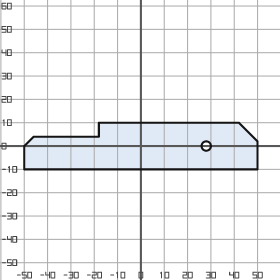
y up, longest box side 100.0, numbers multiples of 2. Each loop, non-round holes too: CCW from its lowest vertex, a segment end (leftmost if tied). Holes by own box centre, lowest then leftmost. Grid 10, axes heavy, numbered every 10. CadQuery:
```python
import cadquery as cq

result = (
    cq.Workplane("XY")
    .moveTo(-50.0, -10.0)
    .lineTo(50.0, -10.0)
    .lineTo(50.0, 2.0)
    .lineTo(42.0, 10.0)
    .lineTo(-18.0, 10.0)
    .lineTo(-18.0, 4.0)
    .lineTo(-46.0, 4.0)
    .lineTo(-50.0, 0.0)
    .close()
    .moveTo(28.0, 0.0)
    .circle(2.0)
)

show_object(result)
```